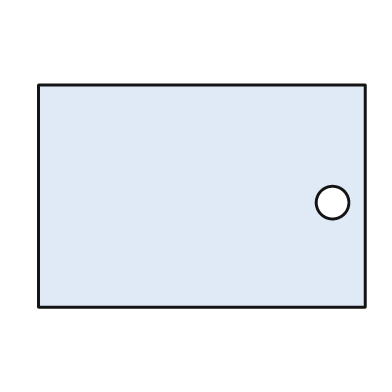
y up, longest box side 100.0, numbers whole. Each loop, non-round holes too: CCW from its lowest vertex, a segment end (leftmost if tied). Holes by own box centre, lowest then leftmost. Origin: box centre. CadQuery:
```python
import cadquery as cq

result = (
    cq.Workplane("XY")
    .moveTo(-50.0, -34.0)
    .lineTo(50.0, -34.0)
    .lineTo(50.0, 34.0)
    .lineTo(-50.0, 34.0)
    .close()
    .moveTo(40.0, -2.0)
    .circle(5.0)
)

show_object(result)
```